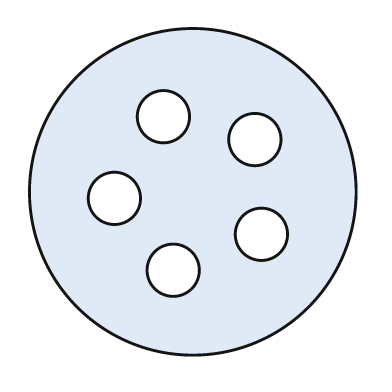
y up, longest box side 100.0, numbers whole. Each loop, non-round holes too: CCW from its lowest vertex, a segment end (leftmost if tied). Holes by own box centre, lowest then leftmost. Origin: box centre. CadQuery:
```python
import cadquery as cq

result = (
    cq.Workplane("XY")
    .moveTo(0.0, 0.0)
    .circle(50.0)
    .moveTo(-6.0, -24.0)
    .circle(8.0)
    .moveTo(21.0, -13.0)
    .circle(8.0)
    .moveTo(-24.0, -2.0)
    .circle(8.0)
    .moveTo(19.0, 16.0)
    .circle(8.0)
    .moveTo(-9.0, 23.0)
    .circle(8.0)
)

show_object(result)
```